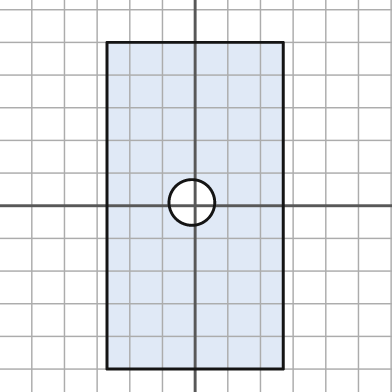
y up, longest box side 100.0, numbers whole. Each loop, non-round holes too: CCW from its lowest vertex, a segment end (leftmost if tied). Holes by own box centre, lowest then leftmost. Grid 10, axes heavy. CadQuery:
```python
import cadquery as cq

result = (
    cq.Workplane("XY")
    .moveTo(-27.0, -50.0)
    .lineTo(27.0, -50.0)
    .lineTo(27.0, 50.0)
    .lineTo(-27.0, 50.0)
    .close()
    .moveTo(-1.0, 1.0)
    .circle(7.0)
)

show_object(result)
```